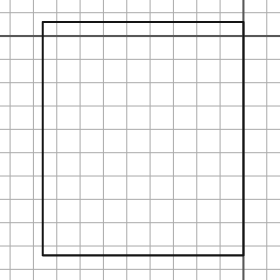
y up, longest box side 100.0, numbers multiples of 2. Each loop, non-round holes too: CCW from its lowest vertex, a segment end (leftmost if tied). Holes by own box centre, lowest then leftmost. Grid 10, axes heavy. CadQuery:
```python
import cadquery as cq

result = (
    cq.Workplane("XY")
    .moveTo(-86.0, -94.0)
    .lineTo(0.0, -94.0)
    .lineTo(0.0, 6.0)
    .lineTo(-86.0, 6.0)
    .close()
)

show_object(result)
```